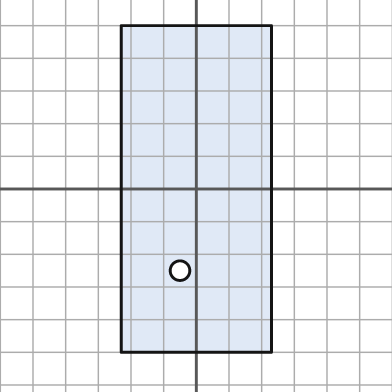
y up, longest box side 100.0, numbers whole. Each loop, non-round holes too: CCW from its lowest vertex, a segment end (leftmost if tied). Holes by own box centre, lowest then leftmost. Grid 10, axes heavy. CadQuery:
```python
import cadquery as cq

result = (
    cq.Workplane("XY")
    .moveTo(-23.0, -50.0)
    .lineTo(23.0, -50.0)
    .lineTo(23.0, 50.0)
    .lineTo(-23.0, 50.0)
    .close()
    .moveTo(-5.0, -25.0)
    .circle(3.0)
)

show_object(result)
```